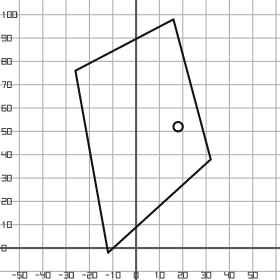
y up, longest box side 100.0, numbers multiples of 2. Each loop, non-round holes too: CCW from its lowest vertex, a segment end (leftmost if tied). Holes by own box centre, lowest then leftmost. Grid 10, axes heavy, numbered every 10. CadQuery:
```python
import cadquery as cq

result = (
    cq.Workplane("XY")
    .moveTo(-12.0, -2.0)
    .lineTo(32.0, 38.0)
    .lineTo(16.0, 98.0)
    .lineTo(-26.0, 76.0)
    .close()
    .moveTo(18.0, 52.0)
    .circle(2.0)
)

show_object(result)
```